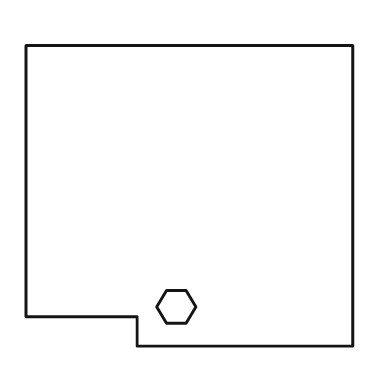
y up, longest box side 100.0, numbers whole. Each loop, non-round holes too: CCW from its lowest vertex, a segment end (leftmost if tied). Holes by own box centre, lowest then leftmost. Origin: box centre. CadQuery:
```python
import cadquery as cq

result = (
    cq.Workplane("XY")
    .moveTo(-16.0, -46.0)
    .lineTo(50.0, -46.0)
    .lineTo(50.0, 46.0)
    .lineTo(-50.0, 46.0)
    .lineTo(-50.0, -37.0)
    .lineTo(-16.0, -37.0)
    .close()
    .moveTo(-7.0, -39.0)
    .lineTo(-1.0, -39.0)
    .lineTo(2.0, -34.0)
    .lineTo(-1.0, -29.0)
    .lineTo(-7.0, -29.0)
    .lineTo(-10.0, -34.0)
    .close()
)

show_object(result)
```